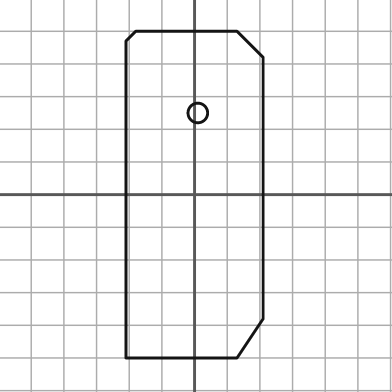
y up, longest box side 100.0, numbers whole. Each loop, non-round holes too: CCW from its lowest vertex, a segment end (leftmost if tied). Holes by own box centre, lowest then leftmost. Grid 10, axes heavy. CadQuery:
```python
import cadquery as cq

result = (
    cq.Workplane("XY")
    .moveTo(-21.0, -50.0)
    .lineTo(13.0, -50.0)
    .lineTo(21.0, -38.0)
    .lineTo(21.0, 42.0)
    .lineTo(13.0, 50.0)
    .lineTo(-18.0, 50.0)
    .lineTo(-21.0, 47.0)
    .close()
    .moveTo(1.0, 25.0)
    .circle(3.0)
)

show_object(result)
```